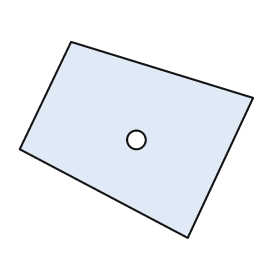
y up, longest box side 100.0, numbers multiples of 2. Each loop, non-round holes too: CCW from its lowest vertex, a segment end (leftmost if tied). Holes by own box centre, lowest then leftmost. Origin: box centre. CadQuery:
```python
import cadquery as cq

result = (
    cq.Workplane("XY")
    .moveTo(22.0, -42.0)
    .lineTo(50.0, 18.0)
    .lineTo(-28.0, 42.0)
    .lineTo(-50.0, -4.0)
    .close()
    .moveTo(0.0, 0.0)
    .circle(4.0)
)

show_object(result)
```